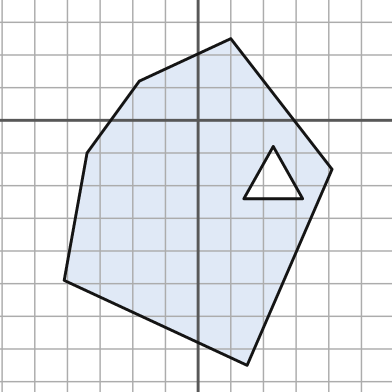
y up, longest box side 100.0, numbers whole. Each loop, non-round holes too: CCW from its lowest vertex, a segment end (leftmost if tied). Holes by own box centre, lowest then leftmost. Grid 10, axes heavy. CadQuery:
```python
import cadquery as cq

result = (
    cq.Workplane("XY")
    .moveTo(15.0, -75.0)
    .lineTo(41.0, -15.0)
    .lineTo(10.0, 25.0)
    .lineTo(-18.0, 12.0)
    .lineTo(-34.0, -10.0)
    .lineTo(-41.0, -49.0)
    .close()
    .moveTo(14.0, -24.0)
    .lineTo(32.0, -24.0)
    .lineTo(23.0, -8.0)
    .close()
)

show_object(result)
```